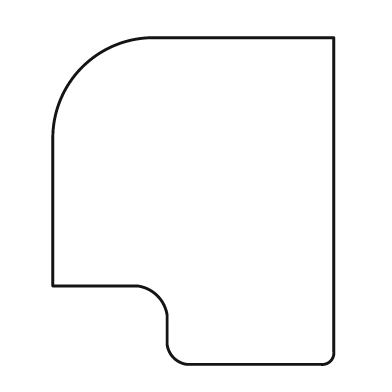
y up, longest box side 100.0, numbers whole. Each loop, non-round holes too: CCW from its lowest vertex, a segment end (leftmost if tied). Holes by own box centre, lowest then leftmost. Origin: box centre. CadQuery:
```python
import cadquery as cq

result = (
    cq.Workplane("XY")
    .moveTo(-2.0, -50.0)
    .lineTo(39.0, -50.0)
    .threePointArc((42.0, -49.0), (43.0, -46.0))
    .lineTo(43.0, 50.0)
    .lineTo(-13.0, 50.0)
    .threePointArc((-34.0, 41.0), (-43.0, 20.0))
    .lineTo(-43.0, -26.0)
    .lineTo(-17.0, -26.0)
    .threePointArc((-11.0, -29.0), (-8.0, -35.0))
    .lineTo(-8.0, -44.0)
    .threePointArc((-6.0, -48.0), (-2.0, -50.0))
    .close()
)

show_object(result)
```